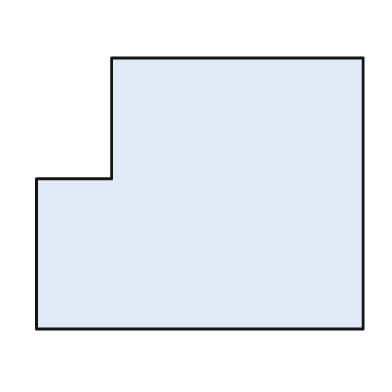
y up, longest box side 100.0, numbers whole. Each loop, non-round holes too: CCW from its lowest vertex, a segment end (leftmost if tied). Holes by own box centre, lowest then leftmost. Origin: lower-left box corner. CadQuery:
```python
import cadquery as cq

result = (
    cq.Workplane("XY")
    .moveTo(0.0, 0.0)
    .lineTo(100.0, 0.0)
    .lineTo(100.0, 83.0)
    .lineTo(23.0, 83.0)
    .lineTo(23.0, 46.0)
    .lineTo(0.0, 46.0)
    .close()
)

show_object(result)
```